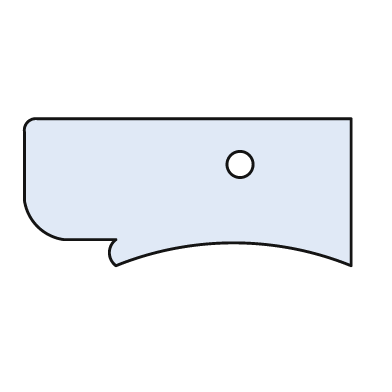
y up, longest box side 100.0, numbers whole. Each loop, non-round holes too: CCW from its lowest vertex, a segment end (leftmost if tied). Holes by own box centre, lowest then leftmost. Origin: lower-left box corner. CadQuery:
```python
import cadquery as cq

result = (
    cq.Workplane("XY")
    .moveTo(28.0, 0.0)
    .threePointArc((64.0, 7.0), (100.0, 0.0))
    .lineTo(100.0, 45.0)
    .lineTo(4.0, 45.0)
    .threePointArc((1.0, 44.0), (0.0, 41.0))
    .lineTo(0.0, 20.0)
    .threePointArc((4.0, 12.0), (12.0, 8.0))
    .lineTo(28.0, 8.0)
    .threePointArc((26.0, 4.0), (28.0, 0.0))
    .close()
    .moveTo(66.0, 31.0)
    .circle(4.0)
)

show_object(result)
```